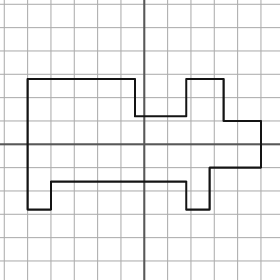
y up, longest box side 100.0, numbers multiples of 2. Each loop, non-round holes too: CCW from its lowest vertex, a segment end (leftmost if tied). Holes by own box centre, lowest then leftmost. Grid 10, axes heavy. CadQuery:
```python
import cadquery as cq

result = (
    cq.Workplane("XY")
    .moveTo(-50.0, -28.0)
    .lineTo(-40.0, -28.0)
    .lineTo(-40.0, -16.0)
    .lineTo(18.0, -16.0)
    .lineTo(18.0, -28.0)
    .lineTo(28.0, -28.0)
    .lineTo(28.0, -10.0)
    .lineTo(50.0, -10.0)
    .lineTo(50.0, 10.0)
    .lineTo(34.0, 10.0)
    .lineTo(34.0, 28.0)
    .lineTo(18.0, 28.0)
    .lineTo(18.0, 12.0)
    .lineTo(-4.0, 12.0)
    .lineTo(-4.0, 28.0)
    .lineTo(-50.0, 28.0)
    .close()
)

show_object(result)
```